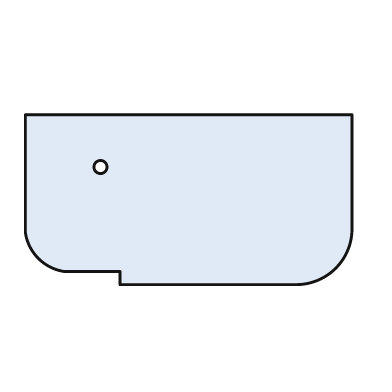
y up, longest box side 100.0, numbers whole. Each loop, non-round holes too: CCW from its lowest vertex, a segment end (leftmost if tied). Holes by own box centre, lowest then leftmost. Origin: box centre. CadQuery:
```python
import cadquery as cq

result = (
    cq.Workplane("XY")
    .moveTo(-21.0, -26.0)
    .lineTo(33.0, -26.0)
    .threePointArc((45.0, -21.0), (50.0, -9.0))
    .lineTo(50.0, 26.0)
    .lineTo(-50.0, 26.0)
    .lineTo(-50.0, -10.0)
    .threePointArc((-46.0, -18.0), (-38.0, -22.0))
    .lineTo(-21.0, -22.0)
    .close()
    .moveTo(-27.0, 10.0)
    .circle(2.0)
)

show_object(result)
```